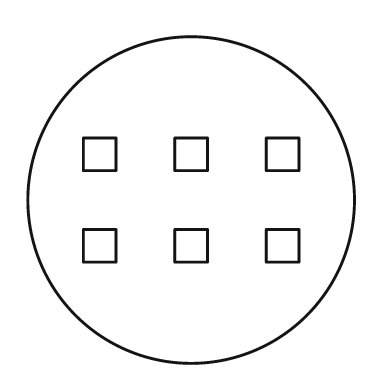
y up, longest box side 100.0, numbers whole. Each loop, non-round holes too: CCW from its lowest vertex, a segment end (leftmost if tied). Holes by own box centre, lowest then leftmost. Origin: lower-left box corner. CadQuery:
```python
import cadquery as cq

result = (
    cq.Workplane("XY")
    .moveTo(50.0, 50.0)
    .circle(50.0)
    .moveTo(17.0, 31.0)
    .lineTo(27.0, 31.0)
    .lineTo(27.0, 41.0)
    .lineTo(17.0, 41.0)
    .close()
    .moveTo(45.0, 31.0)
    .lineTo(55.0, 31.0)
    .lineTo(55.0, 41.0)
    .lineTo(45.0, 41.0)
    .close()
    .moveTo(73.0, 31.0)
    .lineTo(83.0, 31.0)
    .lineTo(83.0, 41.0)
    .lineTo(73.0, 41.0)
    .close()
    .moveTo(17.0, 59.0)
    .lineTo(27.0, 59.0)
    .lineTo(27.0, 69.0)
    .lineTo(17.0, 69.0)
    .close()
    .moveTo(45.0, 59.0)
    .lineTo(55.0, 59.0)
    .lineTo(55.0, 69.0)
    .lineTo(45.0, 69.0)
    .close()
    .moveTo(73.0, 59.0)
    .lineTo(83.0, 59.0)
    .lineTo(83.0, 69.0)
    .lineTo(73.0, 69.0)
    .close()
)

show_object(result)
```